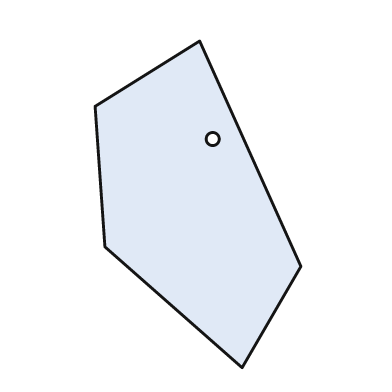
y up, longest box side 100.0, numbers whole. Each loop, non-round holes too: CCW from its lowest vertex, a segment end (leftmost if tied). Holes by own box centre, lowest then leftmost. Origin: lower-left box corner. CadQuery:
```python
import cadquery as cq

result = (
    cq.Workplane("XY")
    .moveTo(45.0, 0.0)
    .lineTo(63.0, 31.0)
    .lineTo(32.0, 100.0)
    .lineTo(0.0, 80.0)
    .lineTo(3.0, 37.0)
    .close()
    .moveTo(36.0, 70.0)
    .circle(2.0)
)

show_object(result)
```